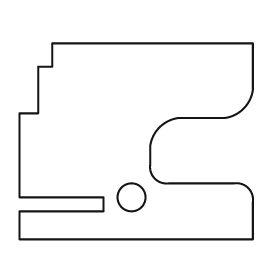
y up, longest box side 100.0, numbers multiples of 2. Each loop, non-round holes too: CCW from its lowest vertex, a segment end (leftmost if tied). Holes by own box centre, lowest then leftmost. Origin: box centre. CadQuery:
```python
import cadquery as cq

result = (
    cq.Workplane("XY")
    .moveTo(-50.0, -42.0)
    .lineTo(50.0, -42.0)
    .lineTo(50.0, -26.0)
    .threePointArc((48.0, -20.0), (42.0, -18.0))
    .lineTo(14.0, -18.0)
    .threePointArc((8.0, -16.0), (6.0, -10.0))
    .lineTo(6.0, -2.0)
    .threePointArc((10.0, 6.0), (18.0, 10.0))
    .lineTo(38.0, 10.0)
    .threePointArc((46.0, 14.0), (50.0, 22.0))
    .lineTo(50.0, 42.0)
    .lineTo(-36.0, 42.0)
    .lineTo(-36.0, 32.0)
    .lineTo(-42.0, 32.0)
    .lineTo(-42.0, 12.0)
    .lineTo(-50.0, 12.0)
    .lineTo(-50.0, -24.0)
    .lineTo(-14.0, -24.0)
    .lineTo(-14.0, -30.0)
    .lineTo(-50.0, -30.0)
    .close()
    .moveTo(-2.0, -24.0)
    .circle(6.0)
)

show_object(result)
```